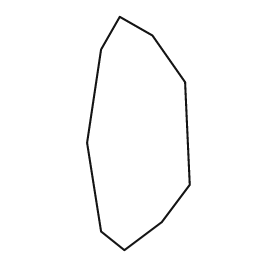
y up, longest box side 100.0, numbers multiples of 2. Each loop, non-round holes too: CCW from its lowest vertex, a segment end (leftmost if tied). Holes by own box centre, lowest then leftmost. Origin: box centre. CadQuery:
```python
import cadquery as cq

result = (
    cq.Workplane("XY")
    .moveTo(-6.0, -50.0)
    .lineTo(10.0, -38.0)
    .lineTo(22.0, -22.0)
    .lineTo(20.0, 22.0)
    .lineTo(6.0, 42.0)
    .lineTo(-8.0, 50.0)
    .lineTo(-16.0, 36.0)
    .lineTo(-22.0, -4.0)
    .lineTo(-16.0, -42.0)
    .close()
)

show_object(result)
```